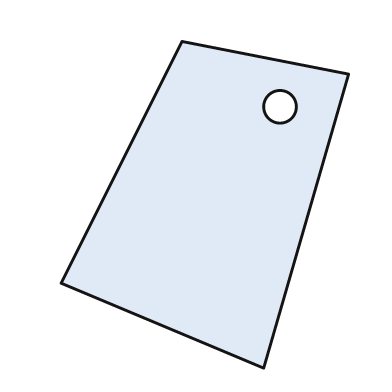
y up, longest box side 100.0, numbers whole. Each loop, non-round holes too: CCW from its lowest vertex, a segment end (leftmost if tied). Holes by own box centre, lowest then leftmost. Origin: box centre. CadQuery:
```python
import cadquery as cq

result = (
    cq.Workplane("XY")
    .moveTo(18.0, -50.0)
    .lineTo(44.0, 40.0)
    .lineTo(-7.0, 50.0)
    .lineTo(-44.0, -24.0)
    .close()
    .moveTo(23.0, 30.0)
    .circle(5.0)
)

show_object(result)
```